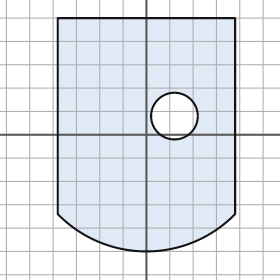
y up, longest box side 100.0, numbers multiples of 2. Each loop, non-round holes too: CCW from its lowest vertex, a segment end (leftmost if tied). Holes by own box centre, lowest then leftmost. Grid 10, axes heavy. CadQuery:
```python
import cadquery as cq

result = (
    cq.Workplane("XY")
    .moveTo(-38.0, -34.0)
    .threePointArc((0.0, -50.0), (38.0, -34.0))
    .lineTo(38.0, 50.0)
    .lineTo(-38.0, 50.0)
    .close()
    .moveTo(12.0, 8.0)
    .circle(10.0)
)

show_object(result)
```